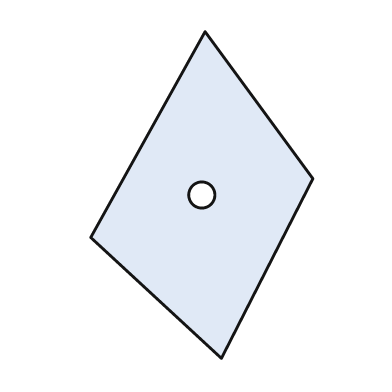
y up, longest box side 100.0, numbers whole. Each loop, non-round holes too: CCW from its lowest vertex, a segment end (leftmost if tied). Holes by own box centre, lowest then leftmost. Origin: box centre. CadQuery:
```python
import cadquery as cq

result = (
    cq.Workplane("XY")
    .moveTo(6.0, -50.0)
    .lineTo(34.0, 5.0)
    .lineTo(1.0, 50.0)
    .lineTo(-34.0, -13.0)
    .close()
    .moveTo(0.0, 0.0)
    .circle(4.0)
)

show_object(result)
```